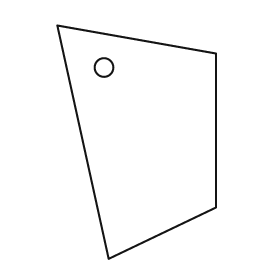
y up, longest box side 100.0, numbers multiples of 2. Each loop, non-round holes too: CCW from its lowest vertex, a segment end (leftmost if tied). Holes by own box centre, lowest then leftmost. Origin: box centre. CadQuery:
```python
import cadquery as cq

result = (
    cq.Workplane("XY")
    .moveTo(-12.0, -50.0)
    .lineTo(34.0, -28.0)
    .lineTo(34.0, 38.0)
    .lineTo(-34.0, 50.0)
    .close()
    .moveTo(-14.0, 32.0)
    .circle(4.0)
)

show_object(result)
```